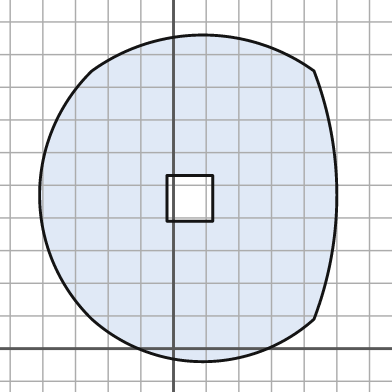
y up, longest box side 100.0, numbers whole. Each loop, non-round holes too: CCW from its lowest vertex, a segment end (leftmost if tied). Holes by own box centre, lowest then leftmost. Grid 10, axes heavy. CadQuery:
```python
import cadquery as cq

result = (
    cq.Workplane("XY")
    .moveTo(-25.0, 9.0)
    .threePointArc((9.0, -4.0), (43.0, 9.0))
    .threePointArc((50.0, 47.0), (43.0, 85.0))
    .threePointArc((9.0, 96.0), (-25.0, 85.0))
    .threePointArc((-41.0, 47.0), (-25.0, 9.0))
    .close()
    .moveTo(-2.0, 39.0)
    .lineTo(12.0, 39.0)
    .lineTo(12.0, 53.0)
    .lineTo(-2.0, 53.0)
    .close()
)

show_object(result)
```